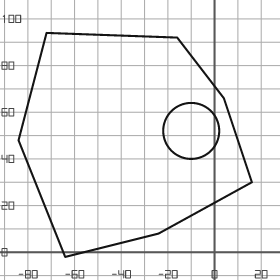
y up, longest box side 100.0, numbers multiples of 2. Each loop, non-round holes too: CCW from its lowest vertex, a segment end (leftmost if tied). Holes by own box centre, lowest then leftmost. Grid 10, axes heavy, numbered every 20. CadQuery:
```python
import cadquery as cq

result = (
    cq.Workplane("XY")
    .moveTo(-64.0, -2.0)
    .lineTo(-24.0, 8.0)
    .lineTo(16.0, 30.0)
    .lineTo(4.0, 66.0)
    .lineTo(-16.0, 92.0)
    .lineTo(-72.0, 94.0)
    .lineTo(-84.0, 48.0)
    .close()
    .moveTo(-10.0, 52.0)
    .circle(12.0)
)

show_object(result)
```